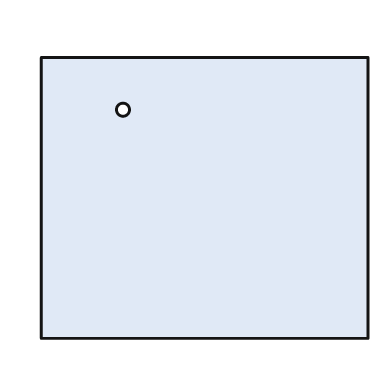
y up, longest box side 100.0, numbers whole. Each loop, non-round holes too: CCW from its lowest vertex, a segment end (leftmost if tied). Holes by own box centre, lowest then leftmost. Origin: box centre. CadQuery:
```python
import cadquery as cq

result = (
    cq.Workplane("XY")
    .moveTo(-50.0, -43.0)
    .lineTo(50.0, -43.0)
    .lineTo(50.0, 43.0)
    .lineTo(-50.0, 43.0)
    .close()
    .moveTo(-25.0, 27.0)
    .circle(2.0)
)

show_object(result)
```